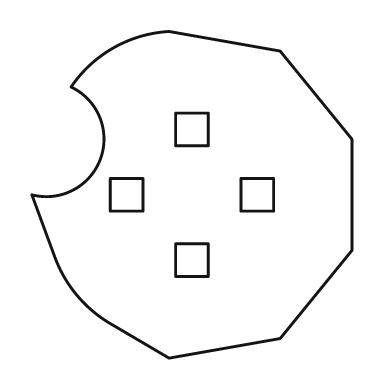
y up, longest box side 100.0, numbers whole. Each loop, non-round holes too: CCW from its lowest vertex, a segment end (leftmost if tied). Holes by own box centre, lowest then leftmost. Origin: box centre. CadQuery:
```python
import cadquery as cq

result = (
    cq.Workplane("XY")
    .moveTo(-7.0, -50.0)
    .lineTo(27.0, -44.0)
    .lineTo(49.0, -17.0)
    .lineTo(49.0, 17.0)
    .lineTo(27.0, 44.0)
    .lineTo(-7.0, 50.0)
    .threePointArc((-24.0, 45.0), (-37.0, 33.0))
    .threePointArc((-28.0, 11.0), (-49.0, 0.0))
    .lineTo(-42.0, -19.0)
    .threePointArc((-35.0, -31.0), (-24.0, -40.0))
    .close()
    .moveTo(-5.0, -25.0)
    .lineTo(5.0, -25.0)
    .lineTo(5.0, -15.0)
    .lineTo(-5.0, -15.0)
    .close()
    .moveTo(-25.0, -5.0)
    .lineTo(-15.0, -5.0)
    .lineTo(-15.0, 5.0)
    .lineTo(-25.0, 5.0)
    .close()
    .moveTo(15.0, -5.0)
    .lineTo(25.0, -5.0)
    .lineTo(25.0, 5.0)
    .lineTo(15.0, 5.0)
    .close()
    .moveTo(-5.0, 15.0)
    .lineTo(5.0, 15.0)
    .lineTo(5.0, 25.0)
    .lineTo(-5.0, 25.0)
    .close()
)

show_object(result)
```